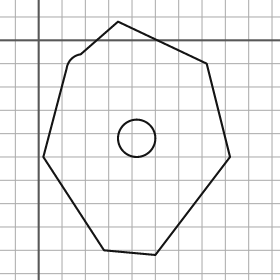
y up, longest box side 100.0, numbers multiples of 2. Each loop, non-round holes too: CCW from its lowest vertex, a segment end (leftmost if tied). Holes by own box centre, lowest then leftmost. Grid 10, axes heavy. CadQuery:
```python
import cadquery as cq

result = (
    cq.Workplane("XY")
    .moveTo(50.0, -92.0)
    .lineTo(82.0, -50.0)
    .lineTo(72.0, -10.0)
    .lineTo(34.0, 8.0)
    .lineTo(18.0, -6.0)
    .threePointArc((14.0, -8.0), (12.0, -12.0))
    .lineTo(2.0, -50.0)
    .lineTo(28.0, -90.0)
    .close()
    .moveTo(42.0, -42.0)
    .circle(8.0)
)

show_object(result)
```